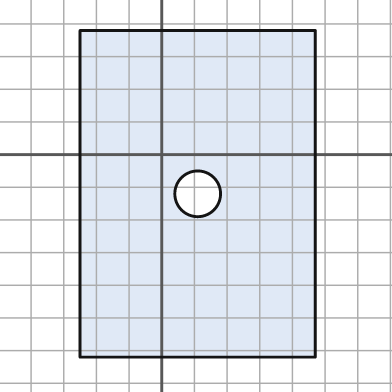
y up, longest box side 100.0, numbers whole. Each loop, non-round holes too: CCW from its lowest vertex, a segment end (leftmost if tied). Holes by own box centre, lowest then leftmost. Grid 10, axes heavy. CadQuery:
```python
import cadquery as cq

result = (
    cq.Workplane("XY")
    .moveTo(-25.0, -62.0)
    .lineTo(47.0, -62.0)
    .lineTo(47.0, 38.0)
    .lineTo(-25.0, 38.0)
    .close()
    .moveTo(11.0, -12.0)
    .circle(7.0)
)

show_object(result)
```